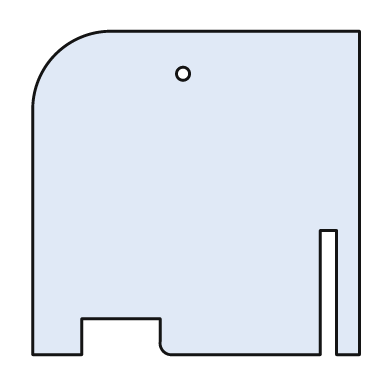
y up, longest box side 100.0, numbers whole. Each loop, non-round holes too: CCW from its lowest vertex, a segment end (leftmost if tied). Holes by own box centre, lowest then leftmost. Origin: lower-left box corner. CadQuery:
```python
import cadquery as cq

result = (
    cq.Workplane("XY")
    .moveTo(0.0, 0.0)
    .lineTo(15.0, 0.0)
    .lineTo(15.0, 11.0)
    .lineTo(39.0, 11.0)
    .lineTo(39.0, 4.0)
    .threePointArc((40.0, 1.0), (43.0, 0.0))
    .lineTo(88.0, 0.0)
    .lineTo(88.0, 38.0)
    .lineTo(93.0, 38.0)
    .lineTo(93.0, 0.0)
    .lineTo(100.0, 0.0)
    .lineTo(100.0, 99.0)
    .lineTo(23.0, 99.0)
    .threePointArc((7.0, 92.0), (0.0, 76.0))
    .close()
    .moveTo(46.0, 86.0)
    .circle(2.0)
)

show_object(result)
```